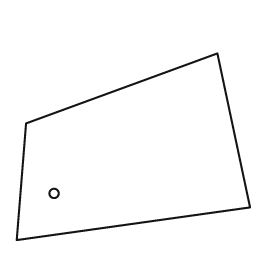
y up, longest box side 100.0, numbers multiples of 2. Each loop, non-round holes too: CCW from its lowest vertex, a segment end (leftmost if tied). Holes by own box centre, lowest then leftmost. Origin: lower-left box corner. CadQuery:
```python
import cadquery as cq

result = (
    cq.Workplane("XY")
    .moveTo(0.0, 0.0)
    .lineTo(100.0, 14.0)
    .lineTo(86.0, 80.0)
    .lineTo(4.0, 50.0)
    .close()
    .moveTo(16.0, 20.0)
    .circle(2.0)
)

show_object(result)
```